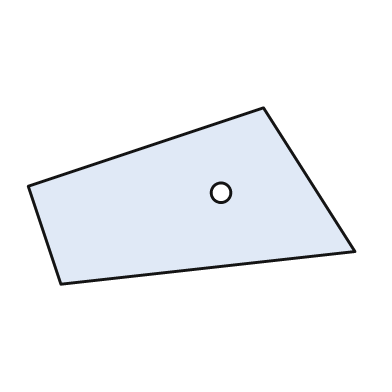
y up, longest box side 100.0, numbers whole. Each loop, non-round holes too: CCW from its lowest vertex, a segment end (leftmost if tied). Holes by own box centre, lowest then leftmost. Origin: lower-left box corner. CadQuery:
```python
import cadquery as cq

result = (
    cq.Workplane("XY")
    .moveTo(10.0, 0.0)
    .lineTo(100.0, 10.0)
    .lineTo(72.0, 54.0)
    .lineTo(0.0, 30.0)
    .close()
    .moveTo(59.0, 28.0)
    .circle(3.0)
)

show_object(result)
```